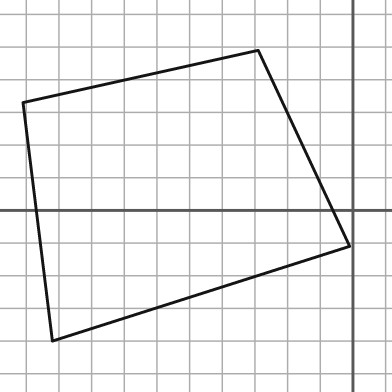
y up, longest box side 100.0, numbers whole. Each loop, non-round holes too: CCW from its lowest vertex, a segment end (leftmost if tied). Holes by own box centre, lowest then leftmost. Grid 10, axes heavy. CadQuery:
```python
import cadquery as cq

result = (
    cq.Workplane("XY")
    .moveTo(-92.0, -40.0)
    .lineTo(-1.0, -11.0)
    .lineTo(-29.0, 49.0)
    .lineTo(-101.0, 33.0)
    .close()
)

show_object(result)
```